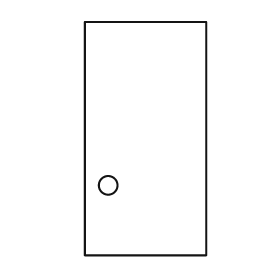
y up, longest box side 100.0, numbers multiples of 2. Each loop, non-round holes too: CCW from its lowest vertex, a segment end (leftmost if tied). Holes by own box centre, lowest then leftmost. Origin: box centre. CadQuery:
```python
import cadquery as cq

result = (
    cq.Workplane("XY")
    .moveTo(-26.0, -50.0)
    .lineTo(26.0, -50.0)
    .lineTo(26.0, 50.0)
    .lineTo(-26.0, 50.0)
    .close()
    .moveTo(-16.0, -20.0)
    .circle(4.0)
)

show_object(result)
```